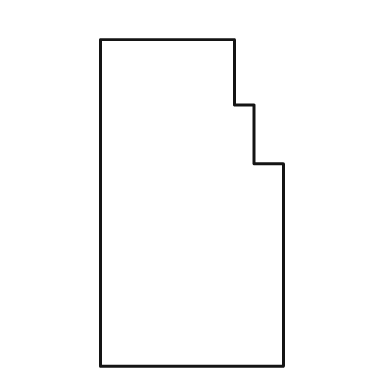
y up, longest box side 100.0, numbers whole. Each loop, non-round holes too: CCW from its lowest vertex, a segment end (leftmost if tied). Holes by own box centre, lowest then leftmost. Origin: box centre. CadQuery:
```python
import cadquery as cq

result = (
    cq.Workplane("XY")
    .moveTo(-28.0, -50.0)
    .lineTo(28.0, -50.0)
    .lineTo(28.0, 12.0)
    .lineTo(19.0, 12.0)
    .lineTo(19.0, 30.0)
    .lineTo(13.0, 30.0)
    .lineTo(13.0, 50.0)
    .lineTo(-28.0, 50.0)
    .close()
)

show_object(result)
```